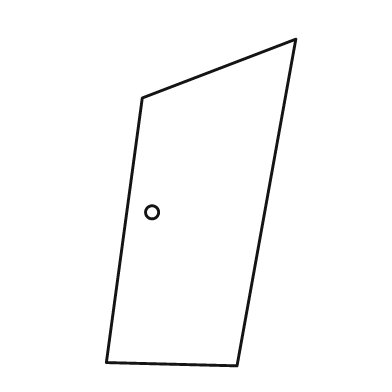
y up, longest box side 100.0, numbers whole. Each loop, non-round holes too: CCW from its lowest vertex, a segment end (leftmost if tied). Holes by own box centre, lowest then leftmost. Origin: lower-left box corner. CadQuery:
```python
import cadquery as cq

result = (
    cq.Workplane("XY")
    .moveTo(40.0, 0.0)
    .lineTo(58.0, 100.0)
    .lineTo(11.0, 82.0)
    .lineTo(0.0, 1.0)
    .close()
    .moveTo(14.0, 47.0)
    .circle(2.0)
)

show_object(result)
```